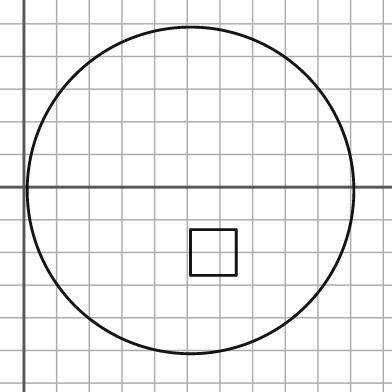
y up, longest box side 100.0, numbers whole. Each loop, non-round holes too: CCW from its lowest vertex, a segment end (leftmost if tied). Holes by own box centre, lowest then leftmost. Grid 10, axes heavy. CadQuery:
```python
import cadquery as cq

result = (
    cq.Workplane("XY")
    .moveTo(51.0, -1.0)
    .circle(50.0)
    .moveTo(51.0, -27.0)
    .lineTo(65.0, -27.0)
    .lineTo(65.0, -13.0)
    .lineTo(51.0, -13.0)
    .close()
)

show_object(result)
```